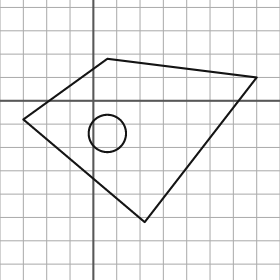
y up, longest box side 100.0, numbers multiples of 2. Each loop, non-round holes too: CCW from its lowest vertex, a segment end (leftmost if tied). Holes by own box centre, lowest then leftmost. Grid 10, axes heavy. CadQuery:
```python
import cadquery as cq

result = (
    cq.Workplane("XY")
    .moveTo(22.0, -52.0)
    .lineTo(70.0, 10.0)
    .lineTo(6.0, 18.0)
    .lineTo(-30.0, -8.0)
    .close()
    .moveTo(6.0, -14.0)
    .circle(8.0)
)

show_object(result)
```